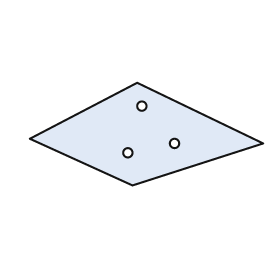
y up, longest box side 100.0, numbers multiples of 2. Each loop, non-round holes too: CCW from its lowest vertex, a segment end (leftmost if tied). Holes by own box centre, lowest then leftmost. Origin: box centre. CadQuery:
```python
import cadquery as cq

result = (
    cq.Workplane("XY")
    .moveTo(-6.0, -22.0)
    .lineTo(50.0, -4.0)
    .lineTo(-4.0, 22.0)
    .lineTo(-50.0, -2.0)
    .close()
    .moveTo(-8.0, -8.0)
    .circle(2.0)
    .moveTo(12.0, -4.0)
    .circle(2.0)
    .moveTo(-2.0, 12.0)
    .circle(2.0)
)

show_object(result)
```